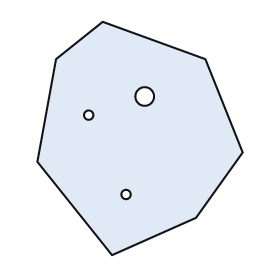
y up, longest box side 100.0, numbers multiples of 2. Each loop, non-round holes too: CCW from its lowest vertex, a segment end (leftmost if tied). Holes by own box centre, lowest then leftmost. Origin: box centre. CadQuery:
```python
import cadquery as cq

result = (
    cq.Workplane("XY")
    .moveTo(-12.0, -50.0)
    .lineTo(24.0, -34.0)
    .lineTo(44.0, -6.0)
    .lineTo(28.0, 34.0)
    .lineTo(-16.0, 50.0)
    .lineTo(-36.0, 34.0)
    .lineTo(-44.0, -10.0)
    .close()
    .moveTo(-6.0, -24.0)
    .circle(2.0)
    .moveTo(-22.0, 10.0)
    .circle(2.0)
    .moveTo(2.0, 18.0)
    .circle(4.0)
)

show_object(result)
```